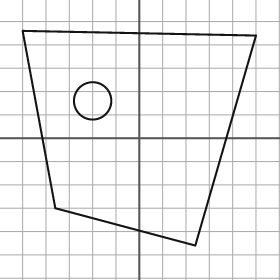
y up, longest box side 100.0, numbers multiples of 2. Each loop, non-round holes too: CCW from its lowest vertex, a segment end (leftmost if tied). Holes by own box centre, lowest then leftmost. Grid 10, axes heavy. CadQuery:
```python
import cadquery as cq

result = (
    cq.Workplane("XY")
    .moveTo(24.0, -46.0)
    .lineTo(50.0, 44.0)
    .lineTo(-50.0, 46.0)
    .lineTo(-36.0, -30.0)
    .close()
    .moveTo(-20.0, 16.0)
    .circle(8.0)
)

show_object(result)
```